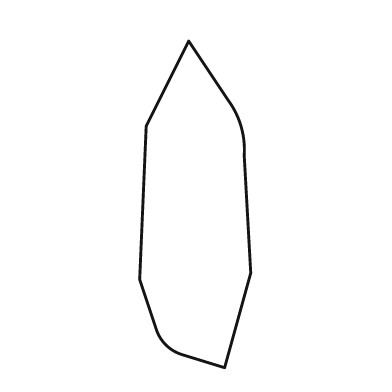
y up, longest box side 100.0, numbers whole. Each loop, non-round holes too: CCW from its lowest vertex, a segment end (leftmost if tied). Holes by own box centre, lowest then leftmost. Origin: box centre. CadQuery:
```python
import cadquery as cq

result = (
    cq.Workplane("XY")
    .moveTo(9.0, -50.0)
    .lineTo(17.0, -21.0)
    .lineTo(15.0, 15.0)
    .threePointArc((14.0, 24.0), (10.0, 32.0))
    .lineTo(-2.0, 50.0)
    .lineTo(-15.0, 24.0)
    .lineTo(-17.0, -23.0)
    .lineTo(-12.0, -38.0)
    .threePointArc((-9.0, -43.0), (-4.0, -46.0))
    .close()
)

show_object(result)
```